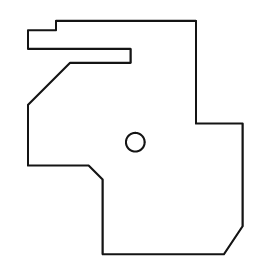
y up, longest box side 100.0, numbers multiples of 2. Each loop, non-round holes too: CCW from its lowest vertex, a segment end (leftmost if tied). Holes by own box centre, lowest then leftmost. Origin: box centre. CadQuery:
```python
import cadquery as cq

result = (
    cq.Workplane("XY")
    .moveTo(-14.0, -50.0)
    .lineTo(38.0, -50.0)
    .lineTo(46.0, -38.0)
    .lineTo(46.0, 6.0)
    .lineTo(26.0, 6.0)
    .lineTo(26.0, 50.0)
    .lineTo(-34.0, 50.0)
    .lineTo(-34.0, 46.0)
    .lineTo(-46.0, 46.0)
    .lineTo(-46.0, 38.0)
    .lineTo(-2.0, 38.0)
    .lineTo(-2.0, 32.0)
    .lineTo(-28.0, 32.0)
    .lineTo(-46.0, 14.0)
    .lineTo(-46.0, -12.0)
    .lineTo(-20.0, -12.0)
    .lineTo(-14.0, -18.0)
    .close()
    .moveTo(0.0, -2.0)
    .circle(4.0)
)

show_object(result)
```